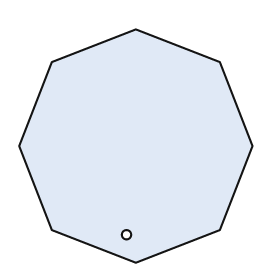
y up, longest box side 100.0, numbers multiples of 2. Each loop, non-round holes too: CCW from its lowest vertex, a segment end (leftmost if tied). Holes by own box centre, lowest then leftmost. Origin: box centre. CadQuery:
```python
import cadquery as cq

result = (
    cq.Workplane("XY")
    .moveTo(0.0, -50.0)
    .lineTo(36.0, -36.0)
    .lineTo(50.0, 0.0)
    .lineTo(36.0, 36.0)
    .lineTo(0.0, 50.0)
    .lineTo(-36.0, 36.0)
    .lineTo(-50.0, 0.0)
    .lineTo(-36.0, -36.0)
    .close()
    .moveTo(-4.0, -38.0)
    .circle(2.0)
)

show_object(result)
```